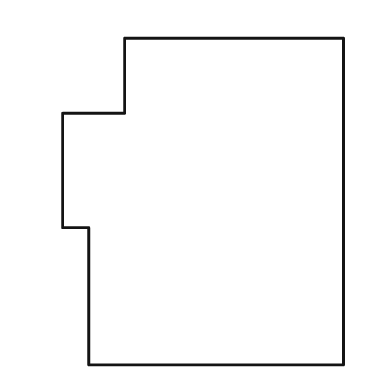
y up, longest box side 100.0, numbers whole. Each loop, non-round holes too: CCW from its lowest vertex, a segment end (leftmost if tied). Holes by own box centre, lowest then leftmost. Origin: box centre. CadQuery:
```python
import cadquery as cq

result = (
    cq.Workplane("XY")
    .moveTo(-35.0, -50.0)
    .lineTo(43.0, -50.0)
    .lineTo(43.0, 50.0)
    .lineTo(-24.0, 50.0)
    .lineTo(-24.0, 27.0)
    .lineTo(-43.0, 27.0)
    .lineTo(-43.0, -8.0)
    .lineTo(-35.0, -8.0)
    .close()
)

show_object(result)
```